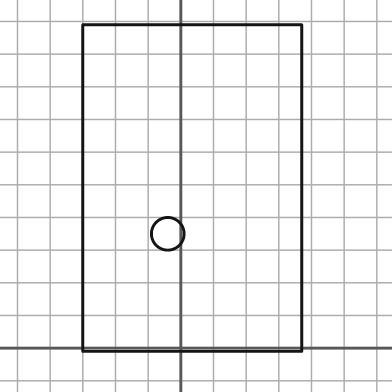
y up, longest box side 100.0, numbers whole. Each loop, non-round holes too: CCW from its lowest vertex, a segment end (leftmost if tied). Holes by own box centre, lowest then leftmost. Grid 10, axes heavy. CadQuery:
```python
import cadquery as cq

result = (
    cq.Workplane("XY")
    .moveTo(-30.0, -1.0)
    .lineTo(37.0, -1.0)
    .lineTo(37.0, 99.0)
    .lineTo(-30.0, 99.0)
    .close()
    .moveTo(-4.0, 35.0)
    .circle(5.0)
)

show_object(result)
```